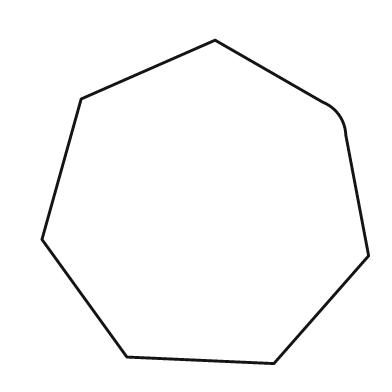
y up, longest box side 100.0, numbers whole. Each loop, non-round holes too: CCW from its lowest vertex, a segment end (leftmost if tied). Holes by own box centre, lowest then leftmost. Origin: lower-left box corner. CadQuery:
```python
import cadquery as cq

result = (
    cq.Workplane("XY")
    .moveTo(71.0, 0.0)
    .lineTo(100.0, 33.0)
    .lineTo(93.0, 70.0)
    .threePointArc((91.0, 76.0), (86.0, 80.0))
    .lineTo(53.0, 99.0)
    .lineTo(12.0, 81.0)
    .lineTo(0.0, 38.0)
    .lineTo(26.0, 2.0)
    .close()
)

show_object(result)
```